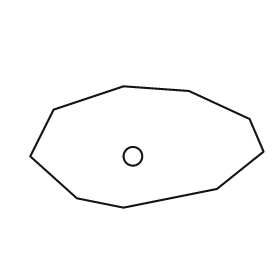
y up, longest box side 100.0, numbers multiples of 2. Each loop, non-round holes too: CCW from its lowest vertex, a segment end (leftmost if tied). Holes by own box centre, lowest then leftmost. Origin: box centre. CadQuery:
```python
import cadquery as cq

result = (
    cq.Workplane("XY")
    .moveTo(-10.0, -26.0)
    .lineTo(30.0, -18.0)
    .lineTo(50.0, -2.0)
    .lineTo(44.0, 12.0)
    .lineTo(18.0, 24.0)
    .lineTo(-10.0, 26.0)
    .lineTo(-40.0, 16.0)
    .lineTo(-50.0, -4.0)
    .lineTo(-30.0, -22.0)
    .close()
    .moveTo(-6.0, -4.0)
    .circle(4.0)
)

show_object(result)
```